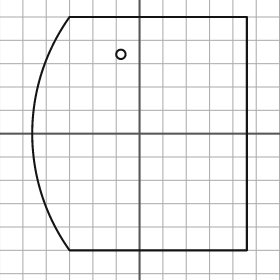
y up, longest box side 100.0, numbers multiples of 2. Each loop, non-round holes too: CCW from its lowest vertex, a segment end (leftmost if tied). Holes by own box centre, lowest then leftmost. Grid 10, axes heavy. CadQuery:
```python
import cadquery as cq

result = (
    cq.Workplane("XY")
    .moveTo(-30.0, -50.0)
    .lineTo(46.0, -50.0)
    .lineTo(46.0, 50.0)
    .lineTo(-30.0, 50.0)
    .threePointArc((-46.0, 0.0), (-30.0, -50.0))
    .close()
    .moveTo(-8.0, 34.0)
    .circle(2.0)
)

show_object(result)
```